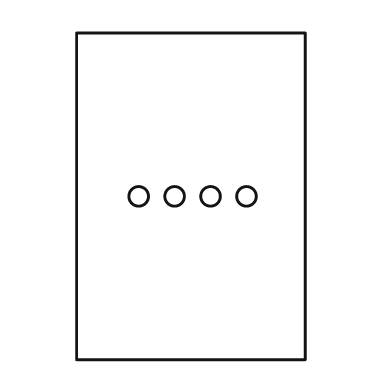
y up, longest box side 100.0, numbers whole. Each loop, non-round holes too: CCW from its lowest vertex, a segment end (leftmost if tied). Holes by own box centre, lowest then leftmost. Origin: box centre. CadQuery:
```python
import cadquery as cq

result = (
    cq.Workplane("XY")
    .moveTo(-35.0, -50.0)
    .lineTo(35.0, -50.0)
    .lineTo(35.0, 50.0)
    .lineTo(-35.0, 50.0)
    .close()
    .moveTo(-16.0, 0.0)
    .circle(3.0)
    .moveTo(-5.0, 0.0)
    .circle(3.0)
    .moveTo(6.0, 0.0)
    .circle(3.0)
    .moveTo(17.0, 0.0)
    .circle(3.0)
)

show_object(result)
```